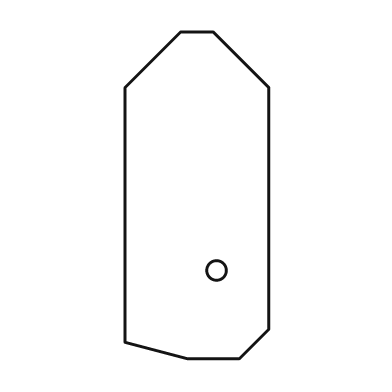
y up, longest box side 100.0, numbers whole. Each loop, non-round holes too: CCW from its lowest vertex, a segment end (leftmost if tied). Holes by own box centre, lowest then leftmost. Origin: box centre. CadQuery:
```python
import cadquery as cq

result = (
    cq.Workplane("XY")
    .moveTo(-3.0, -50.0)
    .lineTo(13.0, -50.0)
    .lineTo(22.0, -41.0)
    .lineTo(22.0, 33.0)
    .lineTo(5.0, 50.0)
    .lineTo(-5.0, 50.0)
    .lineTo(-22.0, 33.0)
    .lineTo(-22.0, -45.0)
    .close()
    .moveTo(6.0, -23.0)
    .circle(3.0)
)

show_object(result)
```